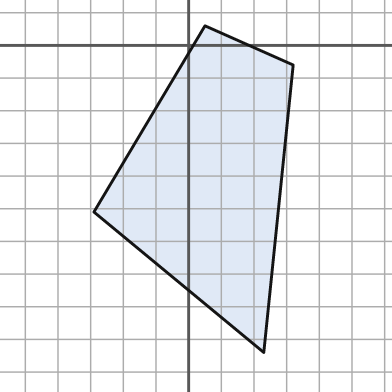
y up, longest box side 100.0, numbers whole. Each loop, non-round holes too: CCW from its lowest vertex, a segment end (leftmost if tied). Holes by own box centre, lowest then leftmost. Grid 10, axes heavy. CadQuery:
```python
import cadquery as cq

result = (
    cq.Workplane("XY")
    .moveTo(23.0, -94.0)
    .lineTo(32.0, -6.0)
    .lineTo(5.0, 6.0)
    .lineTo(-29.0, -51.0)
    .close()
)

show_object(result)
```